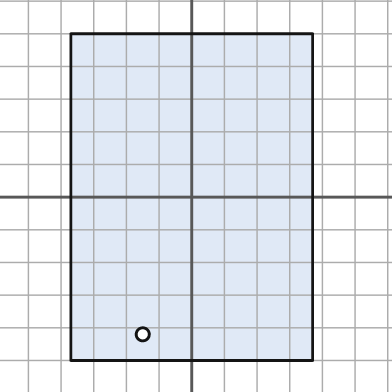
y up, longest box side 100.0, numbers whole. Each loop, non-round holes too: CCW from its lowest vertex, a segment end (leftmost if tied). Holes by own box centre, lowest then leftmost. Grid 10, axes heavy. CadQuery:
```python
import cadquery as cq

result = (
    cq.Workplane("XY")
    .moveTo(-37.0, -50.0)
    .lineTo(37.0, -50.0)
    .lineTo(37.0, 50.0)
    .lineTo(-37.0, 50.0)
    .close()
    .moveTo(-15.0, -42.0)
    .circle(2.0)
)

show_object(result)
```